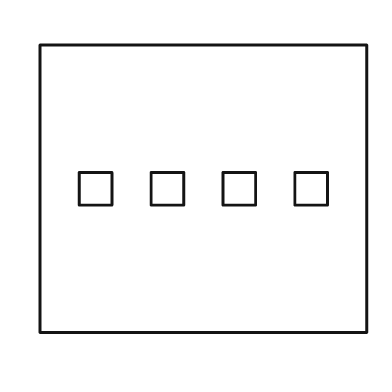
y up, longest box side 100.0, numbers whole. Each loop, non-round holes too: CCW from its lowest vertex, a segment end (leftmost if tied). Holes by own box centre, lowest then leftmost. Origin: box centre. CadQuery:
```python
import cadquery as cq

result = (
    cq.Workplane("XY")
    .moveTo(-50.0, -44.0)
    .lineTo(50.0, -44.0)
    .lineTo(50.0, 44.0)
    .lineTo(-50.0, 44.0)
    .close()
    .moveTo(-38.0, -5.0)
    .lineTo(-28.0, -5.0)
    .lineTo(-28.0, 5.0)
    .lineTo(-38.0, 5.0)
    .close()
    .moveTo(-16.0, -5.0)
    .lineTo(-6.0, -5.0)
    .lineTo(-6.0, 5.0)
    .lineTo(-16.0, 5.0)
    .close()
    .moveTo(6.0, -5.0)
    .lineTo(16.0, -5.0)
    .lineTo(16.0, 5.0)
    .lineTo(6.0, 5.0)
    .close()
    .moveTo(28.0, -5.0)
    .lineTo(38.0, -5.0)
    .lineTo(38.0, 5.0)
    .lineTo(28.0, 5.0)
    .close()
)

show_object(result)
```